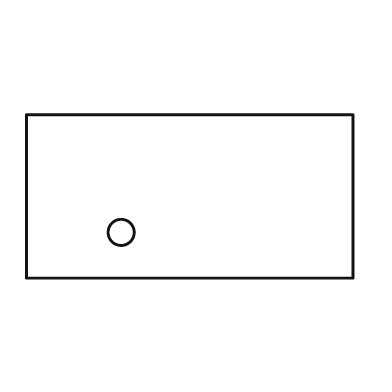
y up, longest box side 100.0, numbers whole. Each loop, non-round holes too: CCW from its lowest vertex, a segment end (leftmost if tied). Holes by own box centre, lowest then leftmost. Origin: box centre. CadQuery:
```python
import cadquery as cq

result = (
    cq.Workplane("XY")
    .moveTo(-50.0, -25.0)
    .lineTo(50.0, -25.0)
    .lineTo(50.0, 25.0)
    .lineTo(-50.0, 25.0)
    .close()
    .moveTo(-21.0, -11.0)
    .circle(4.0)
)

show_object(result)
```